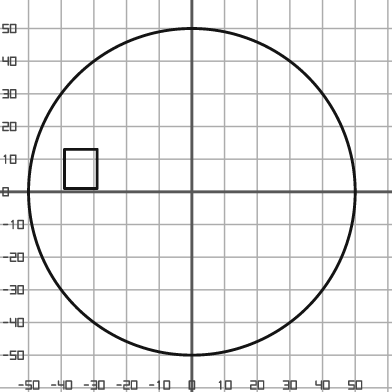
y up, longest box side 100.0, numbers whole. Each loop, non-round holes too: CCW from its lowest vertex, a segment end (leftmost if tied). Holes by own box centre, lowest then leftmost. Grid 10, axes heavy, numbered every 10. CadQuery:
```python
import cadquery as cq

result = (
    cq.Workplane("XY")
    .moveTo(0.0, 0.0)
    .circle(50.0)
    .moveTo(-39.0, 1.0)
    .lineTo(-29.0, 1.0)
    .lineTo(-29.0, 13.0)
    .lineTo(-39.0, 13.0)
    .close()
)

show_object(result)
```